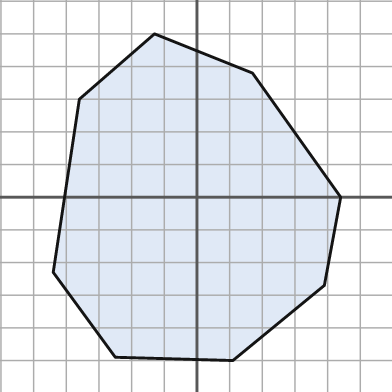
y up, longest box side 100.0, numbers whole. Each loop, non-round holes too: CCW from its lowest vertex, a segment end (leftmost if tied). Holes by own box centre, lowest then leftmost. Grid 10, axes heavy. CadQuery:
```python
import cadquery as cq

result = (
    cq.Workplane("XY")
    .moveTo(11.0, -50.0)
    .lineTo(39.0, -27.0)
    .lineTo(44.0, 0.0)
    .lineTo(17.0, 38.0)
    .lineTo(-13.0, 50.0)
    .lineTo(-36.0, 30.0)
    .lineTo(-44.0, -23.0)
    .lineTo(-25.0, -49.0)
    .close()
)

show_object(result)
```